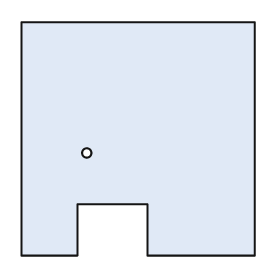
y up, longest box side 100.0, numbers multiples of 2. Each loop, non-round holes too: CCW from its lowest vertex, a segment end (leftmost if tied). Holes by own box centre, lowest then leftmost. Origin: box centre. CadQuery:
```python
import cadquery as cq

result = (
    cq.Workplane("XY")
    .moveTo(-50.0, -50.0)
    .lineTo(-26.0, -50.0)
    .lineTo(-26.0, -28.0)
    .lineTo(4.0, -28.0)
    .lineTo(4.0, -50.0)
    .lineTo(50.0, -50.0)
    .lineTo(50.0, 50.0)
    .lineTo(-50.0, 50.0)
    .close()
    .moveTo(-22.0, -6.0)
    .circle(2.0)
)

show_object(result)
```